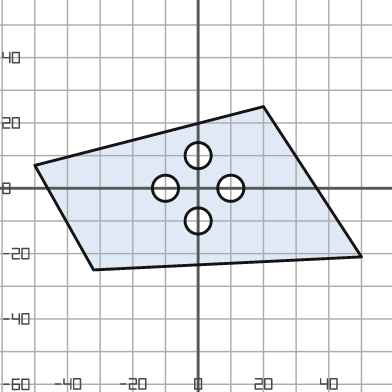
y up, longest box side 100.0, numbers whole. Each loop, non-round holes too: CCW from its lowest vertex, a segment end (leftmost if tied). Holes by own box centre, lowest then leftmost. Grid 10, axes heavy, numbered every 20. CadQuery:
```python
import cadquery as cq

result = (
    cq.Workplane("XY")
    .moveTo(-32.0, -25.0)
    .lineTo(50.0, -21.0)
    .lineTo(20.0, 25.0)
    .lineTo(-50.0, 7.0)
    .close()
    .moveTo(0.0, -10.0)
    .circle(4.0)
    .moveTo(-10.0, 0.0)
    .circle(4.0)
    .moveTo(10.0, 0.0)
    .circle(4.0)
    .moveTo(0.0, 10.0)
    .circle(4.0)
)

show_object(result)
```